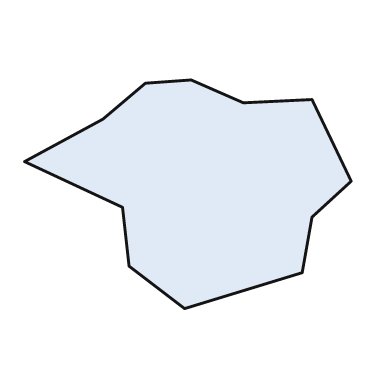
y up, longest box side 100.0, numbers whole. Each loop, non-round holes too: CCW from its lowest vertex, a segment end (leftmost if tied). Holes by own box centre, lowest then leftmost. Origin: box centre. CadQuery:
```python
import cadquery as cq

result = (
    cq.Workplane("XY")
    .moveTo(-1.0, -35.0)
    .lineTo(35.0, -24.0)
    .lineTo(38.0, -7.0)
    .lineTo(50.0, 4.0)
    .lineTo(38.0, 29.0)
    .lineTo(17.0, 28.0)
    .lineTo(1.0, 35.0)
    .lineTo(-13.0, 34.0)
    .lineTo(-26.0, 23.0)
    .lineTo(-50.0, 10.0)
    .lineTo(-20.0, -4.0)
    .lineTo(-18.0, -22.0)
    .close()
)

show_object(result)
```